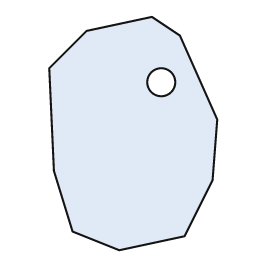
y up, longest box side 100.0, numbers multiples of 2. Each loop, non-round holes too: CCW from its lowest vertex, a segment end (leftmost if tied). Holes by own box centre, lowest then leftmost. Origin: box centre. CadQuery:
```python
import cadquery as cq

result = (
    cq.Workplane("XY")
    .moveTo(-6.0, -50.0)
    .lineTo(22.0, -44.0)
    .lineTo(34.0, -20.0)
    .lineTo(36.0, 6.0)
    .lineTo(20.0, 42.0)
    .lineTo(8.0, 50.0)
    .lineTo(-20.0, 44.0)
    .lineTo(-36.0, 28.0)
    .lineTo(-34.0, -16.0)
    .lineTo(-26.0, -42.0)
    .close()
    .moveTo(12.0, 22.0)
    .circle(6.0)
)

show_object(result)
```